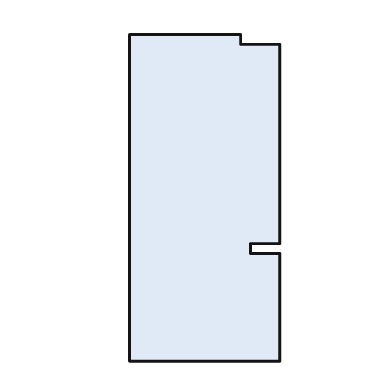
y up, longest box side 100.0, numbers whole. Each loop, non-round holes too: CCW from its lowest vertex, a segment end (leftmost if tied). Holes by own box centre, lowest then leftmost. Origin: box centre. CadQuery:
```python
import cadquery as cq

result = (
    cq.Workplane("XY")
    .moveTo(-23.0, -50.0)
    .lineTo(23.0, -50.0)
    .lineTo(23.0, -17.0)
    .lineTo(14.0, -17.0)
    .lineTo(14.0, -14.0)
    .lineTo(23.0, -14.0)
    .lineTo(23.0, 47.0)
    .lineTo(11.0, 47.0)
    .lineTo(11.0, 50.0)
    .lineTo(-23.0, 50.0)
    .close()
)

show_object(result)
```